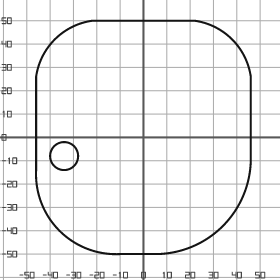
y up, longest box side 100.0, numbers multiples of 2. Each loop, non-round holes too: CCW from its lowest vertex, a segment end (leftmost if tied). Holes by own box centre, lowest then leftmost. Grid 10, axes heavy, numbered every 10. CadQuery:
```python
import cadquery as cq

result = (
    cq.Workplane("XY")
    .moveTo(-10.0, -50.0)
    .lineTo(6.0, -50.0)
    .threePointArc((34.0, -38.0), (46.0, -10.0))
    .lineTo(46.0, 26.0)
    .threePointArc((38.0, 42.0), (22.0, 50.0))
    .lineTo(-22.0, 50.0)
    .threePointArc((-38.0, 42.0), (-46.0, 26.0))
    .lineTo(-46.0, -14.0)
    .threePointArc((-36.0, -40.0), (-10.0, -50.0))
    .close()
    .moveTo(-34.0, -8.0)
    .circle(6.0)
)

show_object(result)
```